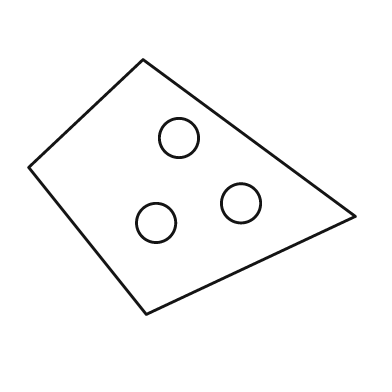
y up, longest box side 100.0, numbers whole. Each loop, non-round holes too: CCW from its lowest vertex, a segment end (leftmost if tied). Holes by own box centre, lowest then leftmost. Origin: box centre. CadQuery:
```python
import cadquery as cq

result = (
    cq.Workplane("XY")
    .moveTo(-14.0, -39.0)
    .lineTo(50.0, -9.0)
    .lineTo(-15.0, 39.0)
    .lineTo(-50.0, 6.0)
    .close()
    .moveTo(-11.0, -11.0)
    .circle(6.0)
    .moveTo(15.0, -5.0)
    .circle(6.0)
    .moveTo(-4.0, 15.0)
    .circle(6.0)
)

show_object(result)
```